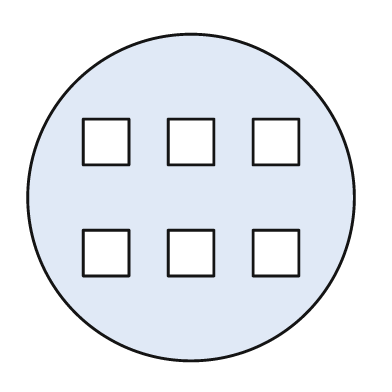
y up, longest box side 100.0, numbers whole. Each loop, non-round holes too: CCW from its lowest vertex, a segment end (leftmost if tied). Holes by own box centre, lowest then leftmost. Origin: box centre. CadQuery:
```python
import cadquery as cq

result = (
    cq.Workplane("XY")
    .moveTo(0.0, 0.0)
    .circle(50.0)
    .moveTo(-33.0, -24.0)
    .lineTo(-19.0, -24.0)
    .lineTo(-19.0, -10.0)
    .lineTo(-33.0, -10.0)
    .close()
    .moveTo(-7.0, -24.0)
    .lineTo(7.0, -24.0)
    .lineTo(7.0, -10.0)
    .lineTo(-7.0, -10.0)
    .close()
    .moveTo(19.0, -24.0)
    .lineTo(33.0, -24.0)
    .lineTo(33.0, -10.0)
    .lineTo(19.0, -10.0)
    .close()
    .moveTo(-33.0, 10.0)
    .lineTo(-19.0, 10.0)
    .lineTo(-19.0, 24.0)
    .lineTo(-33.0, 24.0)
    .close()
    .moveTo(-7.0, 10.0)
    .lineTo(7.0, 10.0)
    .lineTo(7.0, 24.0)
    .lineTo(-7.0, 24.0)
    .close()
    .moveTo(19.0, 10.0)
    .lineTo(33.0, 10.0)
    .lineTo(33.0, 24.0)
    .lineTo(19.0, 24.0)
    .close()
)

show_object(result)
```